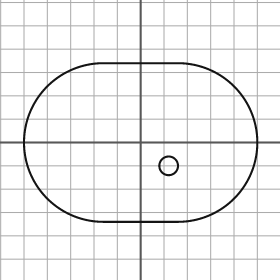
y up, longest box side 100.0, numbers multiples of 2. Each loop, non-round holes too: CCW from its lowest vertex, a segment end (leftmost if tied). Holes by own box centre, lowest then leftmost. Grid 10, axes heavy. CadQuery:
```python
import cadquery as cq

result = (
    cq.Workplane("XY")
    .moveTo(-16.0, -34.0)
    .lineTo(16.0, -34.0)
    .threePointArc((50.0, 0.0), (16.0, 34.0))
    .lineTo(-16.0, 34.0)
    .threePointArc((-50.0, 0.0), (-16.0, -34.0))
    .close()
    .moveTo(12.0, -10.0)
    .circle(4.0)
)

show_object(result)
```